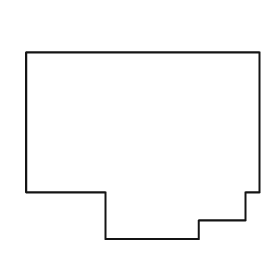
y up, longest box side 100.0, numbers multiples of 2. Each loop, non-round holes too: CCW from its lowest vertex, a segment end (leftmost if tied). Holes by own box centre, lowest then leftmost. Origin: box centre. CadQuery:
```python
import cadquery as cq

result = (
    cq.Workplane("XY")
    .moveTo(-16.0, -40.0)
    .lineTo(24.0, -40.0)
    .lineTo(24.0, -32.0)
    .lineTo(44.0, -32.0)
    .lineTo(44.0, -20.0)
    .lineTo(50.0, -20.0)
    .lineTo(50.0, 40.0)
    .lineTo(-50.0, 40.0)
    .lineTo(-50.0, -20.0)
    .lineTo(-16.0, -20.0)
    .close()
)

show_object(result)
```